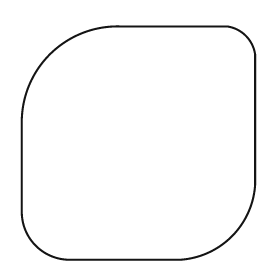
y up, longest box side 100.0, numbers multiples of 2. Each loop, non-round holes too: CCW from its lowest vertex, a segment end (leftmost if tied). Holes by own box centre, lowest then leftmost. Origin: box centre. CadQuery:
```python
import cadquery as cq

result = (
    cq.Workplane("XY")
    .moveTo(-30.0, -50.0)
    .lineTo(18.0, -50.0)
    .threePointArc((40.0, -40.0), (50.0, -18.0))
    .lineTo(50.0, 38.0)
    .threePointArc((46.0, 46.0), (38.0, 50.0))
    .lineTo(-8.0, 50.0)
    .threePointArc((-38.0, 38.0), (-50.0, 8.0))
    .lineTo(-50.0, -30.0)
    .threePointArc((-44.0, -44.0), (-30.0, -50.0))
    .close()
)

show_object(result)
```